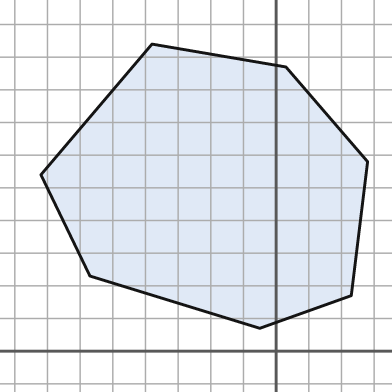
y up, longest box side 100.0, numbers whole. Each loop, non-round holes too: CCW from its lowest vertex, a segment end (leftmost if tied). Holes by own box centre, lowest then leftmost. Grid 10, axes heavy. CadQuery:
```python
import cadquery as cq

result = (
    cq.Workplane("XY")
    .moveTo(-5.0, 7.0)
    .lineTo(23.0, 17.0)
    .lineTo(28.0, 58.0)
    .lineTo(3.0, 87.0)
    .lineTo(-38.0, 94.0)
    .lineTo(-72.0, 54.0)
    .lineTo(-57.0, 23.0)
    .close()
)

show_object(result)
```